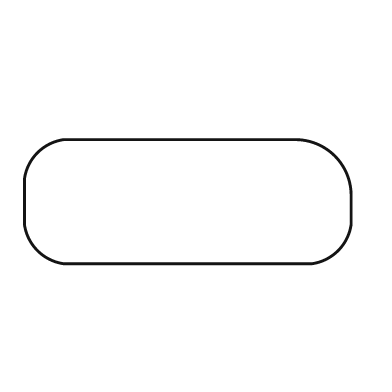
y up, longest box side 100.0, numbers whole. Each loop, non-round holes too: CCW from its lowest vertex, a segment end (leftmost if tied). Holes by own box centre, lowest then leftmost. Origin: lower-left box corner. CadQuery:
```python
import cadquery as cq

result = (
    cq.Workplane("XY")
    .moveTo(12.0, 0.0)
    .lineTo(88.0, 0.0)
    .threePointArc((96.0, 4.0), (100.0, 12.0))
    .lineTo(100.0, 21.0)
    .threePointArc((95.0, 33.0), (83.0, 38.0))
    .lineTo(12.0, 38.0)
    .threePointArc((4.0, 34.0), (0.0, 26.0))
    .lineTo(0.0, 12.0)
    .threePointArc((4.0, 4.0), (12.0, 0.0))
    .close()
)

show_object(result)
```